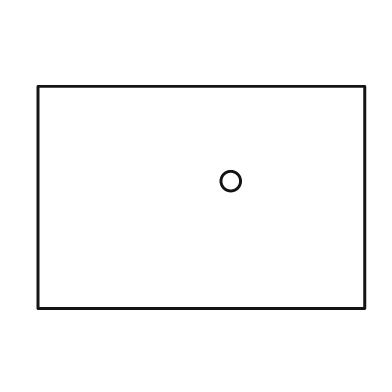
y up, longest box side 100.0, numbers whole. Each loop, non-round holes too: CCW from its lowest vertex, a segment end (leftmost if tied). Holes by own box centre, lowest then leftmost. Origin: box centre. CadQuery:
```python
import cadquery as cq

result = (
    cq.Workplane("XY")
    .moveTo(-50.0, -34.0)
    .lineTo(50.0, -34.0)
    .lineTo(50.0, 34.0)
    .lineTo(-50.0, 34.0)
    .close()
    .moveTo(9.0, 5.0)
    .circle(3.0)
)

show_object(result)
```